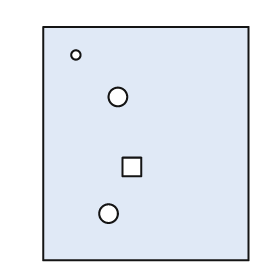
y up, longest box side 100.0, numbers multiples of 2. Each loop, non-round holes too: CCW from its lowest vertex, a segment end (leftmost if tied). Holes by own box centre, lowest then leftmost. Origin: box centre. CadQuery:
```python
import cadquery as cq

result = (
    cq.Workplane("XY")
    .moveTo(-44.0, -50.0)
    .lineTo(44.0, -50.0)
    .lineTo(44.0, 50.0)
    .lineTo(-44.0, 50.0)
    .close()
    .moveTo(-16.0, -30.0)
    .circle(4.0)
    .moveTo(-10.0, -14.0)
    .lineTo(-2.0, -14.0)
    .lineTo(-2.0, -6.0)
    .lineTo(-10.0, -6.0)
    .close()
    .moveTo(-12.0, 20.0)
    .circle(4.0)
    .moveTo(-30.0, 38.0)
    .circle(2.0)
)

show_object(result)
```